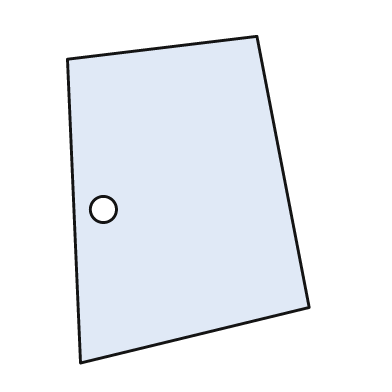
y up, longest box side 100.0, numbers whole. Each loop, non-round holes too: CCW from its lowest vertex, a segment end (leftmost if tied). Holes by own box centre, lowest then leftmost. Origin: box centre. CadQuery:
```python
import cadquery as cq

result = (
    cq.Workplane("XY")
    .moveTo(-33.0, -50.0)
    .lineTo(37.0, -33.0)
    .lineTo(21.0, 50.0)
    .lineTo(-37.0, 43.0)
    .close()
    .moveTo(-26.0, -3.0)
    .circle(4.0)
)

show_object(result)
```